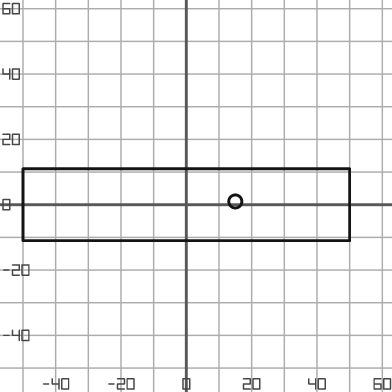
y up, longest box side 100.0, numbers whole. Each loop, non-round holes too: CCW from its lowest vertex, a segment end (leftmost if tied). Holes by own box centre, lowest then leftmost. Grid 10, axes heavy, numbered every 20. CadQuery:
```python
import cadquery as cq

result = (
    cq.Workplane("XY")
    .moveTo(-50.0, -11.0)
    .lineTo(50.0, -11.0)
    .lineTo(50.0, 11.0)
    .lineTo(-50.0, 11.0)
    .close()
    .moveTo(15.0, 1.0)
    .circle(2.0)
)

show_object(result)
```